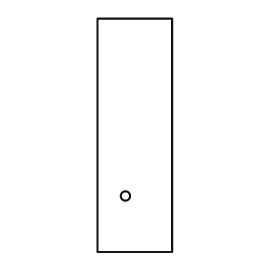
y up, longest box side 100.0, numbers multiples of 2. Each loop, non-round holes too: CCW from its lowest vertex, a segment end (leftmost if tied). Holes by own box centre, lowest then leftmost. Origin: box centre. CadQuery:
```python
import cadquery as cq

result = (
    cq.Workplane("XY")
    .moveTo(-16.0, -50.0)
    .lineTo(16.0, -50.0)
    .lineTo(16.0, 50.0)
    .lineTo(-16.0, 50.0)
    .close()
    .moveTo(-4.0, -26.0)
    .circle(2.0)
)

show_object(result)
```